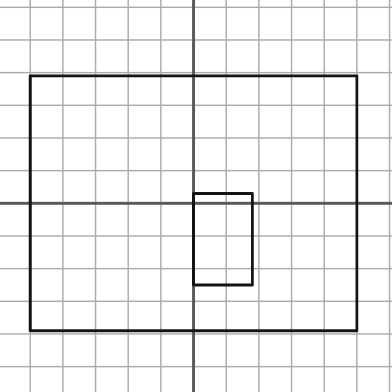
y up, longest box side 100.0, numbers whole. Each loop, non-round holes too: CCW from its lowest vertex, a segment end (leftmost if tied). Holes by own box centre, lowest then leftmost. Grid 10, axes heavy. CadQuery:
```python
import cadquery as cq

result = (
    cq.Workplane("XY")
    .moveTo(-50.0, -39.0)
    .lineTo(50.0, -39.0)
    .lineTo(50.0, 39.0)
    .lineTo(-50.0, 39.0)
    .close()
    .moveTo(0.0, -25.0)
    .lineTo(18.0, -25.0)
    .lineTo(18.0, 3.0)
    .lineTo(0.0, 3.0)
    .close()
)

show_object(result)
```